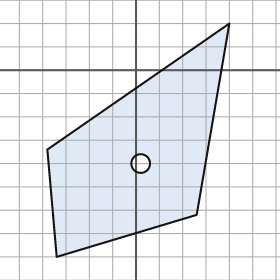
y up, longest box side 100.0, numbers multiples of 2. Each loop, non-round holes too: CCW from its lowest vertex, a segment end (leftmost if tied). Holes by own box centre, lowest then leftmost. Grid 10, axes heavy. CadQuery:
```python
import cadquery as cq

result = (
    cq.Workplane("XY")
    .moveTo(-34.0, -80.0)
    .lineTo(26.0, -62.0)
    .lineTo(40.0, 20.0)
    .lineTo(-38.0, -34.0)
    .close()
    .moveTo(2.0, -40.0)
    .circle(4.0)
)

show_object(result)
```